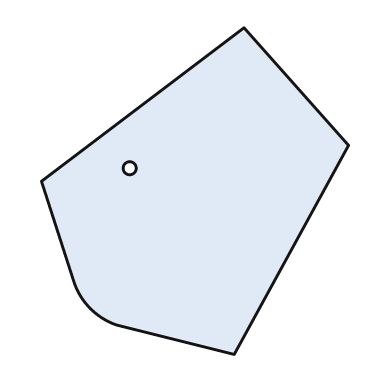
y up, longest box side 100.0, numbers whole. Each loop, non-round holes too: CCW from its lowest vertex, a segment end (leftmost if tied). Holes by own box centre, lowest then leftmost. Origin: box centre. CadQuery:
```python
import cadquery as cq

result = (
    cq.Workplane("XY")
    .moveTo(12.0, -50.0)
    .lineTo(47.0, 14.0)
    .lineTo(15.0, 50.0)
    .lineTo(-47.0, 3.0)
    .lineTo(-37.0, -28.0)
    .threePointArc((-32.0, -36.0), (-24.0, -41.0))
    .close()
    .moveTo(-20.0, 7.0)
    .circle(2.0)
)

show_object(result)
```